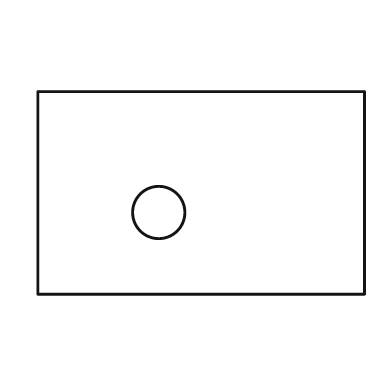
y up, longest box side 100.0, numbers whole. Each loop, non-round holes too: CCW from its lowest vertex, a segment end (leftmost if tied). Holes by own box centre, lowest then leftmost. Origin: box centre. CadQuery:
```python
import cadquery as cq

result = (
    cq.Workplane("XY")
    .moveTo(-50.0, -31.0)
    .lineTo(50.0, -31.0)
    .lineTo(50.0, 31.0)
    .lineTo(-50.0, 31.0)
    .close()
    .moveTo(-13.0, -6.0)
    .circle(8.0)
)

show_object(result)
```